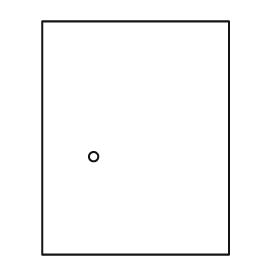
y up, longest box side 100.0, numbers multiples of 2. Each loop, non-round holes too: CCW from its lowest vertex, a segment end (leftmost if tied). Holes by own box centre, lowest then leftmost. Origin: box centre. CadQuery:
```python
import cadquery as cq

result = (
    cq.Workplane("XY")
    .moveTo(-40.0, -50.0)
    .lineTo(40.0, -50.0)
    .lineTo(40.0, 50.0)
    .lineTo(-40.0, 50.0)
    .close()
    .moveTo(-18.0, -8.0)
    .circle(2.0)
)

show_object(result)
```